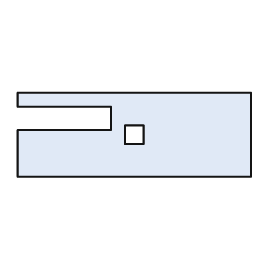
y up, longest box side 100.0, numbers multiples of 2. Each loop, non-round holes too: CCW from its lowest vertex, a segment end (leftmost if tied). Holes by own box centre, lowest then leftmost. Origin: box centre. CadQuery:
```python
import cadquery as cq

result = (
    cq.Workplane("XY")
    .moveTo(-50.0, -18.0)
    .lineTo(50.0, -18.0)
    .lineTo(50.0, 18.0)
    .lineTo(-50.0, 18.0)
    .lineTo(-50.0, 12.0)
    .lineTo(-10.0, 12.0)
    .lineTo(-10.0, 2.0)
    .lineTo(-50.0, 2.0)
    .close()
    .moveTo(-4.0, -4.0)
    .lineTo(4.0, -4.0)
    .lineTo(4.0, 4.0)
    .lineTo(-4.0, 4.0)
    .close()
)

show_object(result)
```